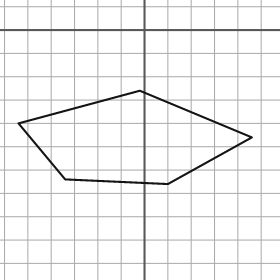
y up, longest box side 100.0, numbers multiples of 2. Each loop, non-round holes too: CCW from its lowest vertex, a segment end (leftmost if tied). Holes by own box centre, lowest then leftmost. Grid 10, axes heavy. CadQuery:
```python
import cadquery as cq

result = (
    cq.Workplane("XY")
    .moveTo(10.0, -66.0)
    .lineTo(46.0, -46.0)
    .lineTo(-2.0, -26.0)
    .lineTo(-54.0, -40.0)
    .lineTo(-34.0, -64.0)
    .close()
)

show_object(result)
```